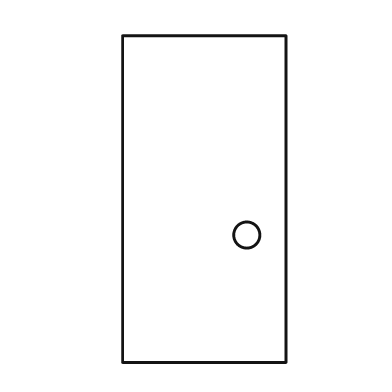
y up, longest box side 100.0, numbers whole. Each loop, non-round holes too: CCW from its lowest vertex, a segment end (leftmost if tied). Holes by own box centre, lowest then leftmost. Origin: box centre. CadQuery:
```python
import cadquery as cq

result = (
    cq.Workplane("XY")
    .moveTo(-25.0, -50.0)
    .lineTo(25.0, -50.0)
    .lineTo(25.0, 50.0)
    .lineTo(-25.0, 50.0)
    .close()
    .moveTo(13.0, -11.0)
    .circle(4.0)
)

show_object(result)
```